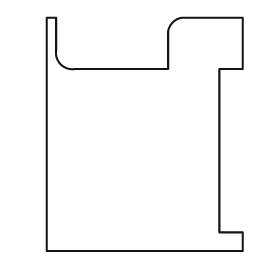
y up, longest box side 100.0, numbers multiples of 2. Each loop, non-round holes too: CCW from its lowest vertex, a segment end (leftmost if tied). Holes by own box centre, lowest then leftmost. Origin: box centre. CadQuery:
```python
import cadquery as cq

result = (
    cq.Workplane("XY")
    .moveTo(-42.0, -50.0)
    .lineTo(42.0, -50.0)
    .lineTo(42.0, -42.0)
    .lineTo(32.0, -42.0)
    .lineTo(32.0, 28.0)
    .lineTo(42.0, 28.0)
    .lineTo(42.0, 50.0)
    .lineTo(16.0, 50.0)
    .threePointArc((12.0, 48.0), (10.0, 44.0))
    .lineTo(10.0, 28.0)
    .lineTo(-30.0, 28.0)
    .threePointArc((-36.0, 30.0), (-38.0, 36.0))
    .lineTo(-38.0, 50.0)
    .lineTo(-42.0, 50.0)
    .close()
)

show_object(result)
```